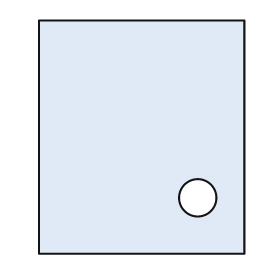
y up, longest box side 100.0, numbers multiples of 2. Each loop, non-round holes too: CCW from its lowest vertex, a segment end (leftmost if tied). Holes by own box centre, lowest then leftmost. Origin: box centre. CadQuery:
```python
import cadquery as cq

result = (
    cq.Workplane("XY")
    .moveTo(-44.0, -50.0)
    .lineTo(44.0, -50.0)
    .lineTo(44.0, 50.0)
    .lineTo(-44.0, 50.0)
    .close()
    .moveTo(24.0, -26.0)
    .circle(8.0)
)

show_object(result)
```